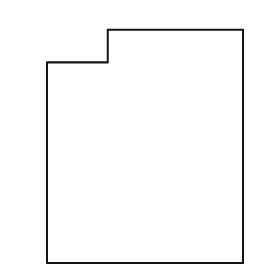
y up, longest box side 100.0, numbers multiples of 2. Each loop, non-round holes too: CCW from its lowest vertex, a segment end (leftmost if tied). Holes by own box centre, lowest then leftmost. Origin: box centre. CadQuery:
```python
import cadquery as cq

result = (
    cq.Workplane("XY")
    .moveTo(-42.0, -50.0)
    .lineTo(42.0, -50.0)
    .lineTo(42.0, 50.0)
    .lineTo(-16.0, 50.0)
    .lineTo(-16.0, 36.0)
    .lineTo(-42.0, 36.0)
    .close()
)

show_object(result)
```